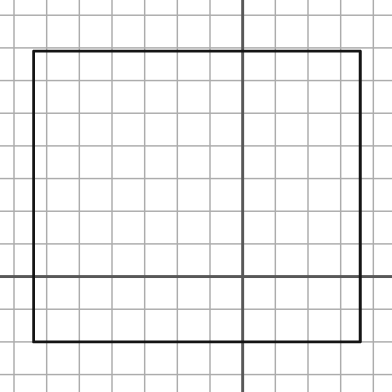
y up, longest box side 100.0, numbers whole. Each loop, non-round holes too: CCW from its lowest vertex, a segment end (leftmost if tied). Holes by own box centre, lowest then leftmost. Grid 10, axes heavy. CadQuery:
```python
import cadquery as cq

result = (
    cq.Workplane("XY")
    .moveTo(-64.0, -20.0)
    .lineTo(36.0, -20.0)
    .lineTo(36.0, 69.0)
    .lineTo(-64.0, 69.0)
    .close()
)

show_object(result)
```